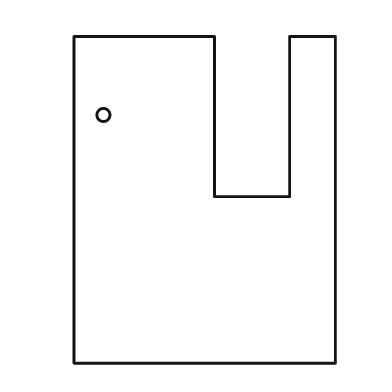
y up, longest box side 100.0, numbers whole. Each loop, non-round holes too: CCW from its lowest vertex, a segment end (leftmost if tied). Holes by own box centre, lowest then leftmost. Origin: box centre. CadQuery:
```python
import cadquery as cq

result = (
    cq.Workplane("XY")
    .moveTo(-40.0, -50.0)
    .lineTo(40.0, -50.0)
    .lineTo(40.0, 50.0)
    .lineTo(26.0, 50.0)
    .lineTo(26.0, 1.0)
    .lineTo(3.0, 1.0)
    .lineTo(3.0, 50.0)
    .lineTo(-40.0, 50.0)
    .close()
    .moveTo(-31.0, 26.0)
    .circle(2.0)
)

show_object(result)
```